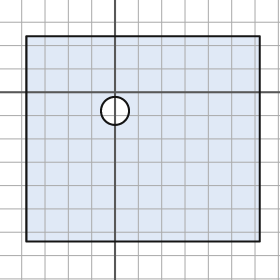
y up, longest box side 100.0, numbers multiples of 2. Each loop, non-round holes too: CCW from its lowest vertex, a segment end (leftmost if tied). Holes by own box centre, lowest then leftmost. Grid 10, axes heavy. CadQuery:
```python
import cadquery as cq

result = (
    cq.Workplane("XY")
    .moveTo(-38.0, -64.0)
    .lineTo(62.0, -64.0)
    .lineTo(62.0, 24.0)
    .lineTo(-38.0, 24.0)
    .close()
    .moveTo(0.0, -8.0)
    .circle(6.0)
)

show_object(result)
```